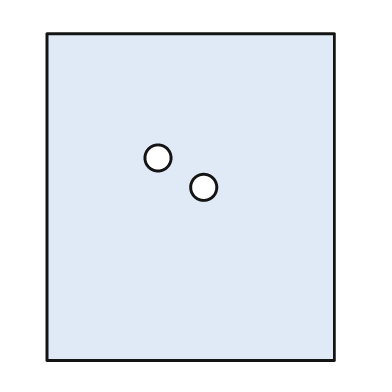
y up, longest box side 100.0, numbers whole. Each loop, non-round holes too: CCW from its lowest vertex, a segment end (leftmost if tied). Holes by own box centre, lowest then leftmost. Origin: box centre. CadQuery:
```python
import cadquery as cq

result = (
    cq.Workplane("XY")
    .moveTo(-44.0, -50.0)
    .lineTo(44.0, -50.0)
    .lineTo(44.0, 50.0)
    .lineTo(-44.0, 50.0)
    .close()
    .moveTo(4.0, 3.0)
    .circle(4.0)
    .moveTo(-10.0, 12.0)
    .circle(4.0)
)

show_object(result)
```